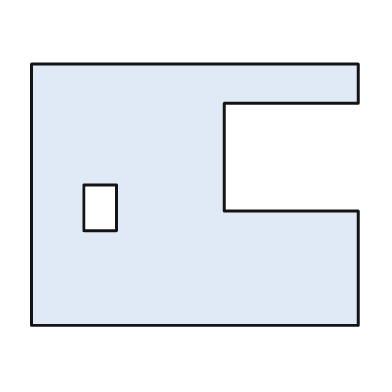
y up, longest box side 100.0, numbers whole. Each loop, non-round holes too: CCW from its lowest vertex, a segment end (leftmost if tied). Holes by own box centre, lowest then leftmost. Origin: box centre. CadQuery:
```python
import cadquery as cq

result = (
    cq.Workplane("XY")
    .moveTo(-50.0, -40.0)
    .lineTo(50.0, -40.0)
    .lineTo(50.0, -5.0)
    .lineTo(9.0, -5.0)
    .lineTo(9.0, 28.0)
    .lineTo(50.0, 28.0)
    .lineTo(50.0, 40.0)
    .lineTo(-50.0, 40.0)
    .close()
    .moveTo(-34.0, -11.0)
    .lineTo(-24.0, -11.0)
    .lineTo(-24.0, 3.0)
    .lineTo(-34.0, 3.0)
    .close()
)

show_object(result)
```